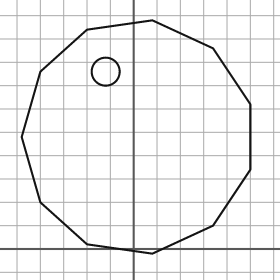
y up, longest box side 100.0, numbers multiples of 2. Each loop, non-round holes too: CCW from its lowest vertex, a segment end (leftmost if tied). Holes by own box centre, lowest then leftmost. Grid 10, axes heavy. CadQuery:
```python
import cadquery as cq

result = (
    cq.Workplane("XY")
    .moveTo(8.0, -2.0)
    .lineTo(34.0, 10.0)
    .lineTo(50.0, 34.0)
    .lineTo(50.0, 62.0)
    .lineTo(34.0, 86.0)
    .lineTo(8.0, 98.0)
    .lineTo(-20.0, 94.0)
    .lineTo(-40.0, 76.0)
    .lineTo(-48.0, 48.0)
    .lineTo(-40.0, 20.0)
    .lineTo(-20.0, 2.0)
    .close()
    .moveTo(-12.0, 76.0)
    .circle(6.0)
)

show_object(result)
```